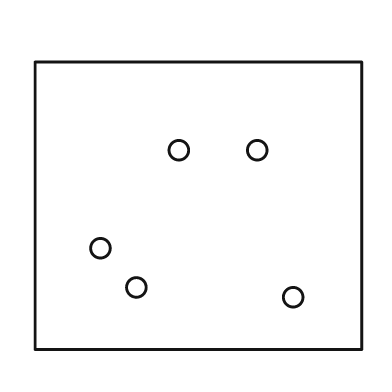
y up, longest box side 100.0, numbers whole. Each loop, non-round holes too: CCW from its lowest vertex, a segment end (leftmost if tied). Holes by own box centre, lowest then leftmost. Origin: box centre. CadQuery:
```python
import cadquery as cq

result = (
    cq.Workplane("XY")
    .moveTo(-50.0, -44.0)
    .lineTo(50.0, -44.0)
    .lineTo(50.0, 44.0)
    .lineTo(-50.0, 44.0)
    .close()
    .moveTo(29.0, -28.0)
    .circle(3.0)
    .moveTo(-19.0, -25.0)
    .circle(3.0)
    .moveTo(-30.0, -13.0)
    .circle(3.0)
    .moveTo(-6.0, 17.0)
    .circle(3.0)
    .moveTo(18.0, 17.0)
    .circle(3.0)
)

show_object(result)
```